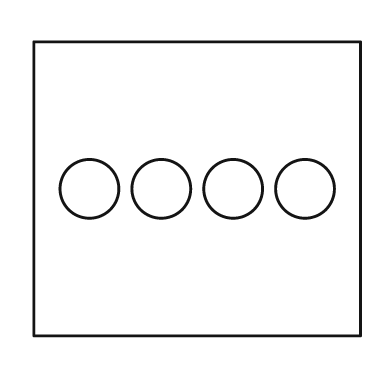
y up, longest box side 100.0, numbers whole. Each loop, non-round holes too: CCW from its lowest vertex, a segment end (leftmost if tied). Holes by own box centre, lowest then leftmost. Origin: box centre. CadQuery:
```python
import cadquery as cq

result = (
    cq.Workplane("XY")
    .moveTo(-50.0, -45.0)
    .lineTo(50.0, -45.0)
    .lineTo(50.0, 45.0)
    .lineTo(-50.0, 45.0)
    .close()
    .moveTo(-33.0, 0.0)
    .circle(9.0)
    .moveTo(-11.0, 0.0)
    .circle(9.0)
    .moveTo(11.0, 0.0)
    .circle(9.0)
    .moveTo(33.0, 0.0)
    .circle(9.0)
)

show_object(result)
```